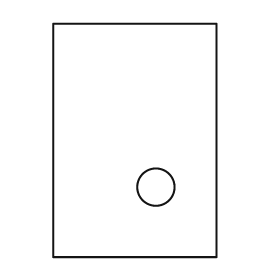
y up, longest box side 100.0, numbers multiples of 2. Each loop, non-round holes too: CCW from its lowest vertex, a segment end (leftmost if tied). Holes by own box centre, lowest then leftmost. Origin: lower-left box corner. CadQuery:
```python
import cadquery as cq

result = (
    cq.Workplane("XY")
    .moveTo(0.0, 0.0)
    .lineTo(70.0, 0.0)
    .lineTo(70.0, 100.0)
    .lineTo(0.0, 100.0)
    .close()
    .moveTo(44.0, 30.0)
    .circle(8.0)
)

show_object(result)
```